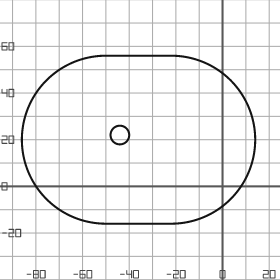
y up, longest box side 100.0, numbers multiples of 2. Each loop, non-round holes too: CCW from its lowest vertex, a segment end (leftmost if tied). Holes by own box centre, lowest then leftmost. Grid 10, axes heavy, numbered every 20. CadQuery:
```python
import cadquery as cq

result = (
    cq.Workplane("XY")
    .moveTo(-50.0, -16.0)
    .lineTo(-22.0, -16.0)
    .threePointArc((14.0, 20.0), (-22.0, 56.0))
    .lineTo(-50.0, 56.0)
    .threePointArc((-86.0, 20.0), (-50.0, -16.0))
    .close()
    .moveTo(-44.0, 22.0)
    .circle(4.0)
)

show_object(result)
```